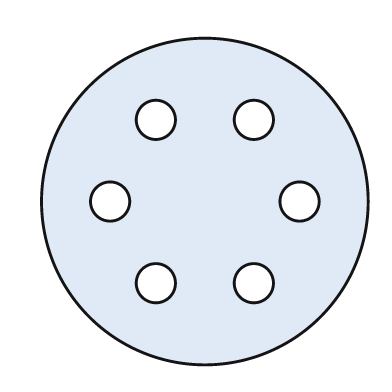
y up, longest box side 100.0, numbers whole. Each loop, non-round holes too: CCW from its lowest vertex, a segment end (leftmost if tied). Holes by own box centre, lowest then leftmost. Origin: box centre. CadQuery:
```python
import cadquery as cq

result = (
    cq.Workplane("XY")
    .moveTo(0.0, 0.0)
    .circle(50.0)
    .moveTo(-15.0, -25.0)
    .circle(6.0)
    .moveTo(15.0, -25.0)
    .circle(6.0)
    .moveTo(-29.0, 0.0)
    .circle(6.0)
    .moveTo(29.0, 0.0)
    .circle(6.0)
    .moveTo(-15.0, 25.0)
    .circle(6.0)
    .moveTo(15.0, 25.0)
    .circle(6.0)
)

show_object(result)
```